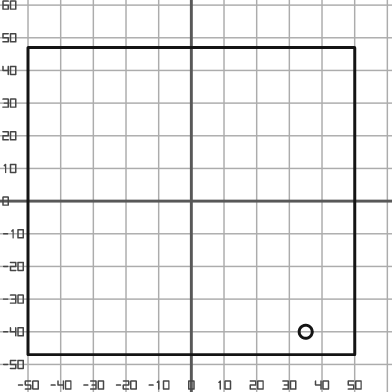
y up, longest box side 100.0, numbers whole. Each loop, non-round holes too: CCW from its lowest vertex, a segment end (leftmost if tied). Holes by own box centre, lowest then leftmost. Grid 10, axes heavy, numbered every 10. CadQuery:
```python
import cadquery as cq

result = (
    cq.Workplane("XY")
    .moveTo(-50.0, -47.0)
    .lineTo(50.0, -47.0)
    .lineTo(50.0, 47.0)
    .lineTo(-50.0, 47.0)
    .close()
    .moveTo(35.0, -40.0)
    .circle(2.0)
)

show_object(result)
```